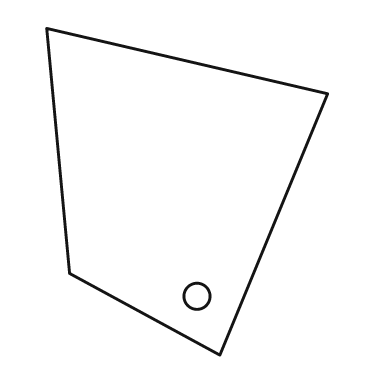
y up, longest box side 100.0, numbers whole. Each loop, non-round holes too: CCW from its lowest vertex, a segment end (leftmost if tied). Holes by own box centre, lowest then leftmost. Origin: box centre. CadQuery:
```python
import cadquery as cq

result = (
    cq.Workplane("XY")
    .moveTo(10.0, -50.0)
    .lineTo(43.0, 30.0)
    .lineTo(-43.0, 50.0)
    .lineTo(-36.0, -25.0)
    .close()
    .moveTo(3.0, -32.0)
    .circle(4.0)
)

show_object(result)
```